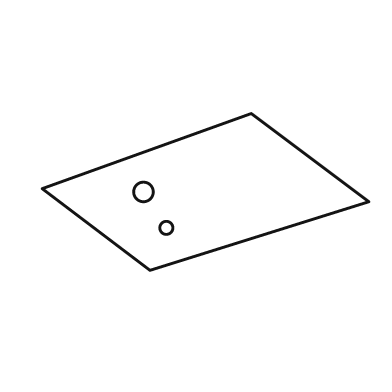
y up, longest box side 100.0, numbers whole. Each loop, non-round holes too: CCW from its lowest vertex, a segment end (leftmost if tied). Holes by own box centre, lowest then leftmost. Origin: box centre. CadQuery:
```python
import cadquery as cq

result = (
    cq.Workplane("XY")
    .moveTo(-17.0, -24.0)
    .lineTo(50.0, -3.0)
    .lineTo(14.0, 24.0)
    .lineTo(-50.0, 1.0)
    .close()
    .moveTo(-12.0, -11.0)
    .circle(2.0)
    .moveTo(-19.0, 0.0)
    .circle(3.0)
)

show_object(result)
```